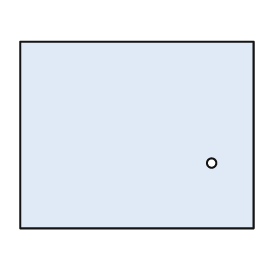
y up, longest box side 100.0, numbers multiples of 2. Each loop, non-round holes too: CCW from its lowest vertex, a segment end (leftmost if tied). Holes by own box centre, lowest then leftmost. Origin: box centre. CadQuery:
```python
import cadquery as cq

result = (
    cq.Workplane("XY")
    .moveTo(-50.0, -40.0)
    .lineTo(50.0, -40.0)
    .lineTo(50.0, 40.0)
    .lineTo(-50.0, 40.0)
    .close()
    .moveTo(32.0, -12.0)
    .circle(2.0)
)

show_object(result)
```